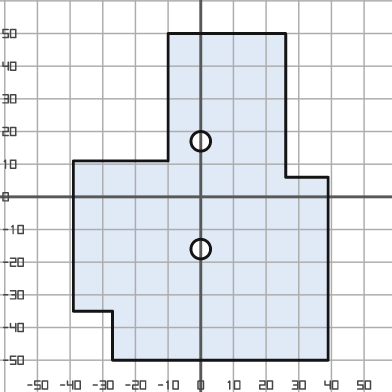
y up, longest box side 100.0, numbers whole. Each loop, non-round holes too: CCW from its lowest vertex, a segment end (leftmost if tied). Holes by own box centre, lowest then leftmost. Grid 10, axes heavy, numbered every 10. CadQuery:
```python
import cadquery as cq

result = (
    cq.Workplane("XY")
    .moveTo(-27.0, -50.0)
    .lineTo(39.0, -50.0)
    .lineTo(39.0, 6.0)
    .lineTo(26.0, 6.0)
    .lineTo(26.0, 50.0)
    .lineTo(-10.0, 50.0)
    .lineTo(-10.0, 11.0)
    .lineTo(-39.0, 11.0)
    .lineTo(-39.0, -35.0)
    .lineTo(-27.0, -35.0)
    .close()
    .moveTo(0.0, -16.0)
    .circle(3.0)
    .moveTo(0.0, 17.0)
    .circle(3.0)
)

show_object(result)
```